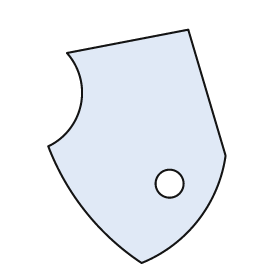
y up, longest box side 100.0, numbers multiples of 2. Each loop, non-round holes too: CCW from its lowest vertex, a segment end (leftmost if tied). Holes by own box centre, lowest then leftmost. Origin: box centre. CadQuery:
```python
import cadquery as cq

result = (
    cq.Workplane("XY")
    .moveTo(2.0, -50.0)
    .threePointArc((26.0, -32.0), (38.0, -4.0))
    .lineTo(22.0, 50.0)
    .lineTo(-30.0, 40.0)
    .threePointArc((-24.0, 18.0), (-38.0, 0.0))
    .threePointArc((-22.0, -28.0), (2.0, -50.0))
    .close()
    .moveTo(14.0, -16.0)
    .circle(6.0)
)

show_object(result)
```